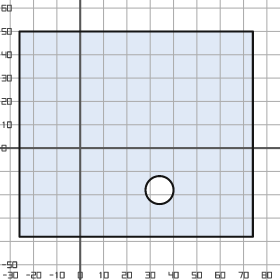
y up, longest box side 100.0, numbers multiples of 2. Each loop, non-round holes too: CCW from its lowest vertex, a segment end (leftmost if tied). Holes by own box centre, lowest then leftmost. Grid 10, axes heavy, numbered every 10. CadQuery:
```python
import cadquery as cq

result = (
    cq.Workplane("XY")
    .moveTo(-26.0, -38.0)
    .lineTo(74.0, -38.0)
    .lineTo(74.0, 50.0)
    .lineTo(-26.0, 50.0)
    .close()
    .moveTo(34.0, -18.0)
    .circle(6.0)
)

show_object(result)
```